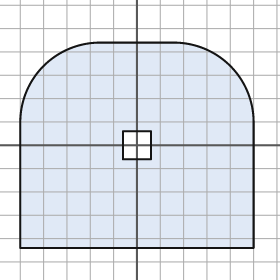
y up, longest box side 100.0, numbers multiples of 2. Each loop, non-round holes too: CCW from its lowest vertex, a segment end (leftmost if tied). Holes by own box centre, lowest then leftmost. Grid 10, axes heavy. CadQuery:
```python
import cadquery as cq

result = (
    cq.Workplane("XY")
    .moveTo(-50.0, -44.0)
    .lineTo(50.0, -44.0)
    .lineTo(50.0, 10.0)
    .threePointArc((40.0, 34.0), (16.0, 44.0))
    .lineTo(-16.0, 44.0)
    .threePointArc((-40.0, 34.0), (-50.0, 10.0))
    .close()
    .moveTo(-6.0, -6.0)
    .lineTo(6.0, -6.0)
    .lineTo(6.0, 6.0)
    .lineTo(-6.0, 6.0)
    .close()
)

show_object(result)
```